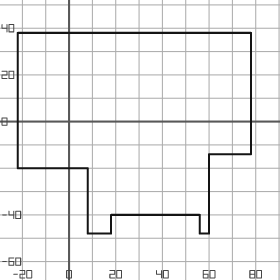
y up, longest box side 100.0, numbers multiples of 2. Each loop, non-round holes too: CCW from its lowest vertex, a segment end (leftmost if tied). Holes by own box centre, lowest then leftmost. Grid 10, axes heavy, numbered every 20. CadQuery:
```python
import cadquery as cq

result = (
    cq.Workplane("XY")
    .moveTo(8.0, -48.0)
    .lineTo(18.0, -48.0)
    .lineTo(18.0, -40.0)
    .lineTo(56.0, -40.0)
    .lineTo(56.0, -48.0)
    .lineTo(60.0, -48.0)
    .lineTo(60.0, -14.0)
    .lineTo(78.0, -14.0)
    .lineTo(78.0, 38.0)
    .lineTo(-22.0, 38.0)
    .lineTo(-22.0, -20.0)
    .lineTo(8.0, -20.0)
    .close()
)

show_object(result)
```